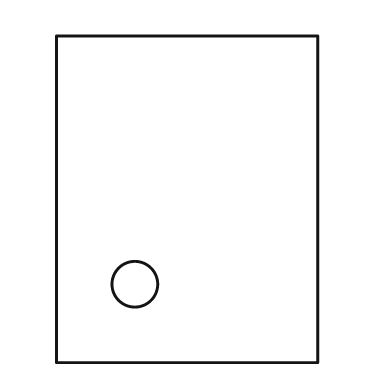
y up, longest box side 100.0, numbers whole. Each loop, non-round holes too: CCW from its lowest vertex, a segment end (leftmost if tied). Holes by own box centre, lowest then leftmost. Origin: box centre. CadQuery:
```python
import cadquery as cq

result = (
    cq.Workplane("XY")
    .moveTo(-40.0, -50.0)
    .lineTo(40.0, -50.0)
    .lineTo(40.0, 50.0)
    .lineTo(-40.0, 50.0)
    .close()
    .moveTo(-16.0, -26.0)
    .circle(7.0)
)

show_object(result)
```